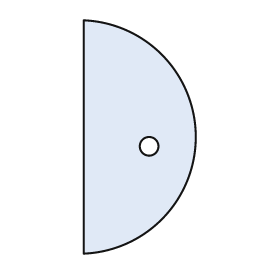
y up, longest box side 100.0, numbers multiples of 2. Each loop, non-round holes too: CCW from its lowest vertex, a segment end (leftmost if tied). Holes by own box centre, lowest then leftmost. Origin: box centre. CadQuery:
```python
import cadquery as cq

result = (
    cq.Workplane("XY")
    .moveTo(-24.0, -50.0)
    .threePointArc((24.0, 0.0), (-24.0, 50.0))
    .close()
    .moveTo(4.0, -4.0)
    .circle(4.0)
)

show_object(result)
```